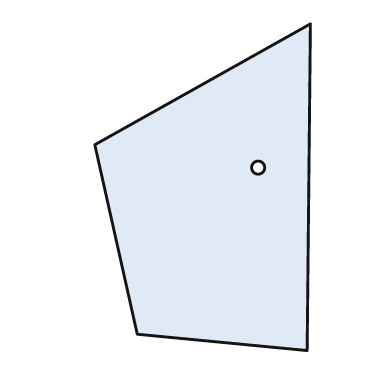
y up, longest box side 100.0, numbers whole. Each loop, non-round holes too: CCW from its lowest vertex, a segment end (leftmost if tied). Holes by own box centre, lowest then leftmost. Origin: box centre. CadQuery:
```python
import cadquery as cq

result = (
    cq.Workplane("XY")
    .moveTo(32.0, -50.0)
    .lineTo(33.0, 50.0)
    .lineTo(-33.0, 13.0)
    .lineTo(-20.0, -45.0)
    .close()
    .moveTo(17.0, 6.0)
    .circle(2.0)
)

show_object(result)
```